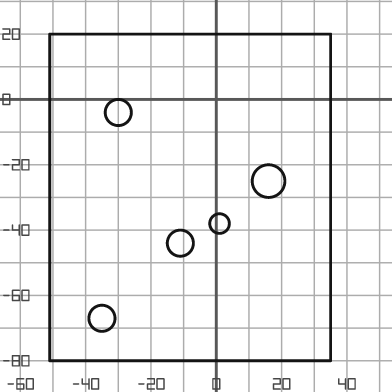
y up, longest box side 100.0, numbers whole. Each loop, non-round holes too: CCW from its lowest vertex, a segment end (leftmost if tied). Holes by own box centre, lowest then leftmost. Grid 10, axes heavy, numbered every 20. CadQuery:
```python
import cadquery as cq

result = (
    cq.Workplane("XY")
    .moveTo(-51.0, -80.0)
    .lineTo(35.0, -80.0)
    .lineTo(35.0, 20.0)
    .lineTo(-51.0, 20.0)
    .close()
    .moveTo(-35.0, -67.0)
    .circle(4.0)
    .moveTo(-11.0, -44.0)
    .circle(4.0)
    .moveTo(1.0, -38.0)
    .circle(3.0)
    .moveTo(16.0, -25.0)
    .circle(5.0)
    .moveTo(-30.0, -4.0)
    .circle(4.0)
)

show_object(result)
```